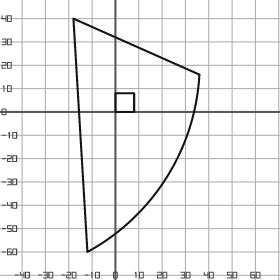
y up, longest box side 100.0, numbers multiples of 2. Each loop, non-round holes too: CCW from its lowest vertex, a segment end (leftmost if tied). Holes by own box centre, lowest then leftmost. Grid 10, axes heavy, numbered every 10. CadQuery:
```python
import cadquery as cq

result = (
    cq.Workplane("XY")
    .moveTo(-12.0, -60.0)
    .threePointArc((22.0, -28.0), (36.0, 16.0))
    .lineTo(-18.0, 40.0)
    .close()
    .moveTo(0.0, 0.0)
    .lineTo(8.0, 0.0)
    .lineTo(8.0, 8.0)
    .lineTo(0.0, 8.0)
    .close()
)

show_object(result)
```